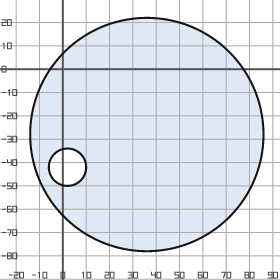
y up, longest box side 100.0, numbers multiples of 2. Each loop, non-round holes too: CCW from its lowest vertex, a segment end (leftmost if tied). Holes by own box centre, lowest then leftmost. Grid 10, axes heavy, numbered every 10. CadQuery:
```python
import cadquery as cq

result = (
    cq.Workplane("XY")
    .moveTo(36.0, -28.0)
    .circle(50.0)
    .moveTo(2.0, -42.0)
    .circle(8.0)
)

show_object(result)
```